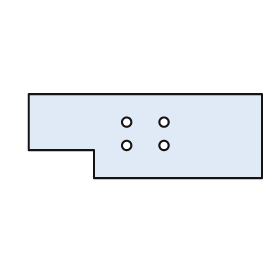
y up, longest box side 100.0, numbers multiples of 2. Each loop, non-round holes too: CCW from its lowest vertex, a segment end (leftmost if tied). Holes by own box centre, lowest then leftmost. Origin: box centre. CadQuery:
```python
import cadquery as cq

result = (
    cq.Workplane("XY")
    .moveTo(-22.0, -18.0)
    .lineTo(50.0, -18.0)
    .lineTo(50.0, 18.0)
    .lineTo(-50.0, 18.0)
    .lineTo(-50.0, -6.0)
    .lineTo(-22.0, -6.0)
    .close()
    .moveTo(-8.0, -4.0)
    .circle(2.0)
    .moveTo(8.0, -4.0)
    .circle(2.0)
    .moveTo(-8.0, 6.0)
    .circle(2.0)
    .moveTo(8.0, 6.0)
    .circle(2.0)
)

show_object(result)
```